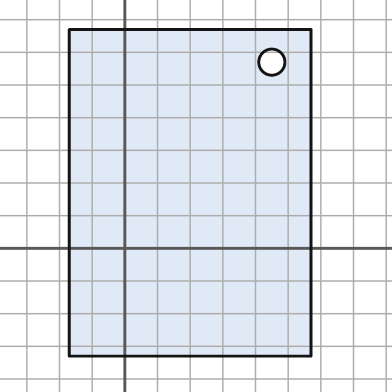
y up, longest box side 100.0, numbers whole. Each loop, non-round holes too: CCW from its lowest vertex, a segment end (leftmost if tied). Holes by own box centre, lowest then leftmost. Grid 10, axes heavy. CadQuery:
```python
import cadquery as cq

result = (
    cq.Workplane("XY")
    .moveTo(-17.0, -33.0)
    .lineTo(57.0, -33.0)
    .lineTo(57.0, 67.0)
    .lineTo(-17.0, 67.0)
    .close()
    .moveTo(45.0, 57.0)
    .circle(4.0)
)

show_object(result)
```